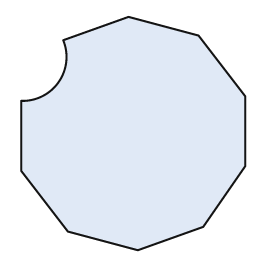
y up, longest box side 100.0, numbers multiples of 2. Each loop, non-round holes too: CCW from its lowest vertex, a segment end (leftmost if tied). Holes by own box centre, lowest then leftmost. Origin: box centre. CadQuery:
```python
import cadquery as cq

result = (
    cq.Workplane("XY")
    .moveTo(2.0, -50.0)
    .lineTo(30.0, -40.0)
    .lineTo(48.0, -14.0)
    .lineTo(48.0, 16.0)
    .lineTo(28.0, 42.0)
    .lineTo(-2.0, 50.0)
    .lineTo(-30.0, 40.0)
    .threePointArc((-32.0, 22.0), (-48.0, 14.0))
    .lineTo(-48.0, -16.0)
    .lineTo(-28.0, -42.0)
    .close()
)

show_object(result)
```